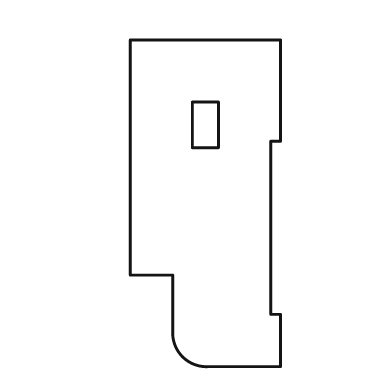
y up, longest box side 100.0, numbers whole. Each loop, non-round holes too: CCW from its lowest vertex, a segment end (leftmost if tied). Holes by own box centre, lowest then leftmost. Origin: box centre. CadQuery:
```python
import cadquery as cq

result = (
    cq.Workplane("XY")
    .moveTo(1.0, -50.0)
    .lineTo(23.0, -50.0)
    .lineTo(23.0, -34.0)
    .lineTo(20.0, -34.0)
    .lineTo(20.0, 19.0)
    .lineTo(23.0, 19.0)
    .lineTo(23.0, 50.0)
    .lineTo(-23.0, 50.0)
    .lineTo(-23.0, -22.0)
    .lineTo(-10.0, -22.0)
    .lineTo(-10.0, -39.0)
    .threePointArc((-7.0, -47.0), (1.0, -50.0))
    .close()
    .moveTo(-4.0, 17.0)
    .lineTo(4.0, 17.0)
    .lineTo(4.0, 31.0)
    .lineTo(-4.0, 31.0)
    .close()
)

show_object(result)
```